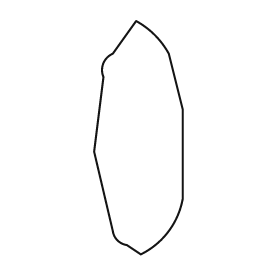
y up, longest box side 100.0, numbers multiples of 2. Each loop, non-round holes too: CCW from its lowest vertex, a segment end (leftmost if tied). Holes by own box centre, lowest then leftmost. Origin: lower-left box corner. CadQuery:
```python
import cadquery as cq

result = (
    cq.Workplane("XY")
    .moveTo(20.0, 0.0)
    .threePointArc((32.0, 10.0), (38.0, 24.0))
    .lineTo(38.0, 62.0)
    .lineTo(32.0, 86.0)
    .threePointArc((26.0, 94.0), (18.0, 100.0))
    .lineTo(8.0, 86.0)
    .threePointArc((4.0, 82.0), (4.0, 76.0))
    .lineTo(0.0, 44.0)
    .lineTo(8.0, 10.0)
    .threePointArc((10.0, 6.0), (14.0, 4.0))
    .close()
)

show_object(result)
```